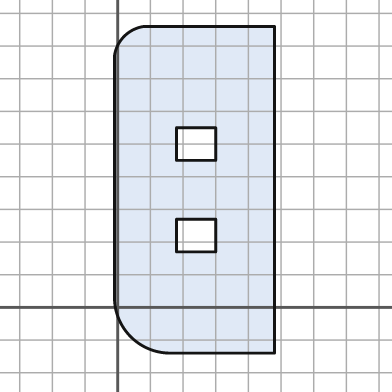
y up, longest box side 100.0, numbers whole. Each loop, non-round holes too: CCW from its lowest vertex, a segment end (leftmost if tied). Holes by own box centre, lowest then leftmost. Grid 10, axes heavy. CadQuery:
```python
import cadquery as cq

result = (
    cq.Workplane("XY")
    .moveTo(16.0, -14.0)
    .lineTo(48.0, -14.0)
    .lineTo(48.0, 86.0)
    .lineTo(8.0, 86.0)
    .threePointArc((2.0, 83.0), (-1.0, 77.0))
    .lineTo(-1.0, 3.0)
    .threePointArc((4.0, -9.0), (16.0, -14.0))
    .close()
    .moveTo(18.0, 17.0)
    .lineTo(30.0, 17.0)
    .lineTo(30.0, 27.0)
    .lineTo(18.0, 27.0)
    .close()
    .moveTo(18.0, 45.0)
    .lineTo(30.0, 45.0)
    .lineTo(30.0, 55.0)
    .lineTo(18.0, 55.0)
    .close()
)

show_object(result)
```